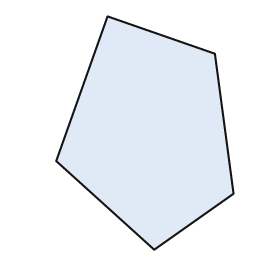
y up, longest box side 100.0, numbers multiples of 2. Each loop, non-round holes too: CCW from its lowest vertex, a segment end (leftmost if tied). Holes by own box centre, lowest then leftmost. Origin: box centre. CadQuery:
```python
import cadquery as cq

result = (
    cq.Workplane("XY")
    .moveTo(4.0, -50.0)
    .lineTo(38.0, -26.0)
    .lineTo(30.0, 34.0)
    .lineTo(-16.0, 50.0)
    .lineTo(-38.0, -12.0)
    .close()
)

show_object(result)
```